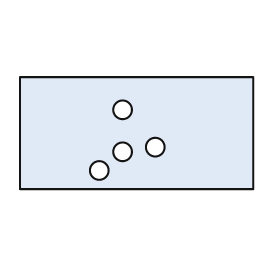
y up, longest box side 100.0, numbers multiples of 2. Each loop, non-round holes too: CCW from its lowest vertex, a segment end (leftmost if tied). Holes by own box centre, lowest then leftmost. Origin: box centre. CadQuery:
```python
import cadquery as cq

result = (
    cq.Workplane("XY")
    .moveTo(-50.0, -24.0)
    .lineTo(50.0, -24.0)
    .lineTo(50.0, 24.0)
    .lineTo(-50.0, 24.0)
    .close()
    .moveTo(-16.0, -16.0)
    .circle(4.0)
    .moveTo(-6.0, -8.0)
    .circle(4.0)
    .moveTo(8.0, -6.0)
    .circle(4.0)
    .moveTo(-6.0, 10.0)
    .circle(4.0)
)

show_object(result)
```